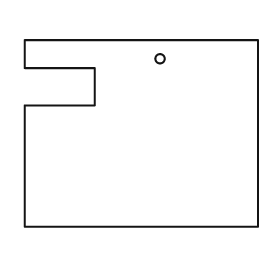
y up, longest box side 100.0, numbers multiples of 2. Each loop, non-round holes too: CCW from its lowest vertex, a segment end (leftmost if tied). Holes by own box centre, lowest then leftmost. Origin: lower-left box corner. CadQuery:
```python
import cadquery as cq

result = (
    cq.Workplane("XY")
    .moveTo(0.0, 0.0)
    .lineTo(100.0, 0.0)
    .lineTo(100.0, 80.0)
    .lineTo(0.0, 80.0)
    .lineTo(0.0, 68.0)
    .lineTo(30.0, 68.0)
    .lineTo(30.0, 52.0)
    .lineTo(0.0, 52.0)
    .close()
    .moveTo(58.0, 72.0)
    .circle(2.0)
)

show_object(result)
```